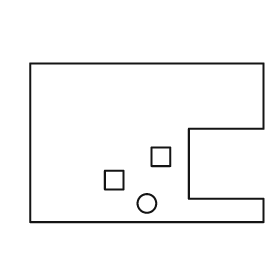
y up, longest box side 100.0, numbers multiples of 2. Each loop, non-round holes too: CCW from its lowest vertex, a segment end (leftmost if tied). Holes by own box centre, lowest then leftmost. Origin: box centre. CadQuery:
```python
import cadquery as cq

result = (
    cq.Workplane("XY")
    .moveTo(-50.0, -34.0)
    .lineTo(50.0, -34.0)
    .lineTo(50.0, -24.0)
    .lineTo(18.0, -24.0)
    .lineTo(18.0, 6.0)
    .lineTo(50.0, 6.0)
    .lineTo(50.0, 34.0)
    .lineTo(-50.0, 34.0)
    .close()
    .moveTo(0.0, -26.0)
    .circle(4.0)
    .moveTo(-18.0, -20.0)
    .lineTo(-10.0, -20.0)
    .lineTo(-10.0, -12.0)
    .lineTo(-18.0, -12.0)
    .close()
    .moveTo(2.0, -10.0)
    .lineTo(10.0, -10.0)
    .lineTo(10.0, -2.0)
    .lineTo(2.0, -2.0)
    .close()
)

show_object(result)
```